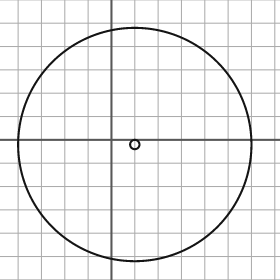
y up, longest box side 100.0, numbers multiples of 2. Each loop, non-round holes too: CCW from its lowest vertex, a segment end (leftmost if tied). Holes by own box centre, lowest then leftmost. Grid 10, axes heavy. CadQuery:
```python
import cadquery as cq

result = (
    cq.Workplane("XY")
    .moveTo(10.0, -2.0)
    .circle(50.0)
    .moveTo(10.0, -2.0)
    .circle(2.0)
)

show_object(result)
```